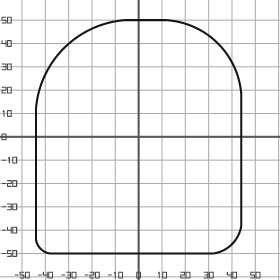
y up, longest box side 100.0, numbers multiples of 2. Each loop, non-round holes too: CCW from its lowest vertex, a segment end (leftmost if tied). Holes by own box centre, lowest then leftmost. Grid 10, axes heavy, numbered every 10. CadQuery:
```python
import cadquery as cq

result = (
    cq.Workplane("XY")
    .moveTo(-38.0, -50.0)
    .lineTo(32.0, -50.0)
    .threePointArc((40.0, -46.0), (44.0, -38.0))
    .lineTo(44.0, 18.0)
    .threePointArc((34.0, 40.0), (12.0, 50.0))
    .lineTo(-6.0, 50.0)
    .threePointArc((-32.0, 38.0), (-44.0, 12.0))
    .lineTo(-44.0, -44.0)
    .threePointArc((-42.0, -48.0), (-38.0, -50.0))
    .close()
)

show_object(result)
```